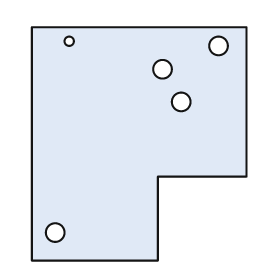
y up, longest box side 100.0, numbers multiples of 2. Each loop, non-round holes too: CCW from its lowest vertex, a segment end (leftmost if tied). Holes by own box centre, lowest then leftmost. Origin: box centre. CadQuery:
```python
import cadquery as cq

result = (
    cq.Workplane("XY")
    .moveTo(-46.0, -50.0)
    .lineTo(8.0, -50.0)
    .lineTo(8.0, -14.0)
    .lineTo(46.0, -14.0)
    .lineTo(46.0, 50.0)
    .lineTo(-46.0, 50.0)
    .close()
    .moveTo(-36.0, -38.0)
    .circle(4.0)
    .moveTo(18.0, 18.0)
    .circle(4.0)
    .moveTo(10.0, 32.0)
    .circle(4.0)
    .moveTo(34.0, 42.0)
    .circle(4.0)
    .moveTo(-30.0, 44.0)
    .circle(2.0)
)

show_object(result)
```